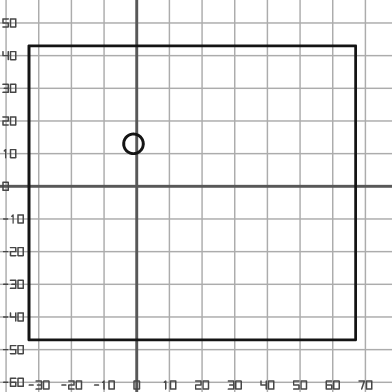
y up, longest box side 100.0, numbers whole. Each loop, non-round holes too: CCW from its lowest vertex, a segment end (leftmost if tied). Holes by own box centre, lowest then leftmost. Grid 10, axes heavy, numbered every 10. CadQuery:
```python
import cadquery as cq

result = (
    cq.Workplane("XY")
    .moveTo(-33.0, -47.0)
    .lineTo(67.0, -47.0)
    .lineTo(67.0, 43.0)
    .lineTo(-33.0, 43.0)
    .close()
    .moveTo(-1.0, 13.0)
    .circle(3.0)
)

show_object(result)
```